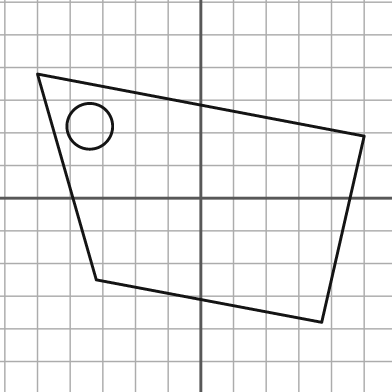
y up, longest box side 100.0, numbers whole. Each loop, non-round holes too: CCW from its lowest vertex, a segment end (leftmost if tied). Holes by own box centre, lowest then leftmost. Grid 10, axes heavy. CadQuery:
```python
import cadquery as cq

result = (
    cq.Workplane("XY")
    .moveTo(37.0, -38.0)
    .lineTo(50.0, 19.0)
    .lineTo(-50.0, 38.0)
    .lineTo(-32.0, -25.0)
    .close()
    .moveTo(-34.0, 22.0)
    .circle(7.0)
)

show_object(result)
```